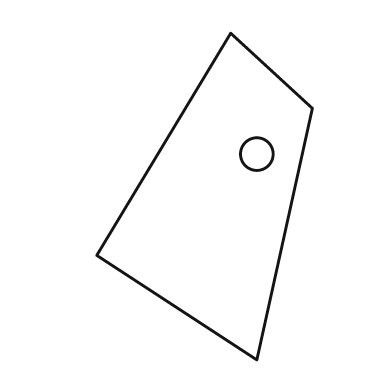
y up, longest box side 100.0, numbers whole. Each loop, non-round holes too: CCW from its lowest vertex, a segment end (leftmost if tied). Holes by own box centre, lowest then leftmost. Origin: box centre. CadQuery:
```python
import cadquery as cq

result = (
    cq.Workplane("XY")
    .moveTo(16.0, -50.0)
    .lineTo(33.0, 27.0)
    .lineTo(8.0, 50.0)
    .lineTo(-33.0, -18.0)
    .close()
    .moveTo(16.0, 13.0)
    .circle(5.0)
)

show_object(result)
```